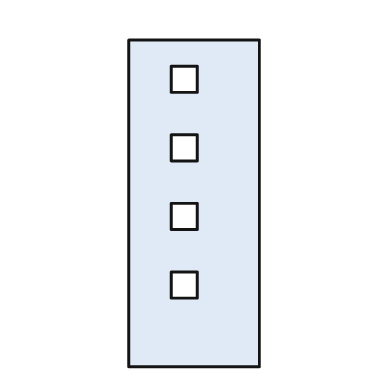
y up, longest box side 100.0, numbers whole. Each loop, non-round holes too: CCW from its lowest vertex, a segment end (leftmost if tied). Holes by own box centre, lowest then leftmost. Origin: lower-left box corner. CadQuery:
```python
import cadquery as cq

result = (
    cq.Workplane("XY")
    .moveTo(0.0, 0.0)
    .lineTo(40.0, 0.0)
    .lineTo(40.0, 100.0)
    .lineTo(0.0, 100.0)
    .close()
    .moveTo(13.0, 21.0)
    .lineTo(21.0, 21.0)
    .lineTo(21.0, 29.0)
    .lineTo(13.0, 29.0)
    .close()
    .moveTo(13.0, 42.0)
    .lineTo(21.0, 42.0)
    .lineTo(21.0, 50.0)
    .lineTo(13.0, 50.0)
    .close()
    .moveTo(13.0, 63.0)
    .lineTo(21.0, 63.0)
    .lineTo(21.0, 71.0)
    .lineTo(13.0, 71.0)
    .close()
    .moveTo(13.0, 84.0)
    .lineTo(21.0, 84.0)
    .lineTo(21.0, 92.0)
    .lineTo(13.0, 92.0)
    .close()
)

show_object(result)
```